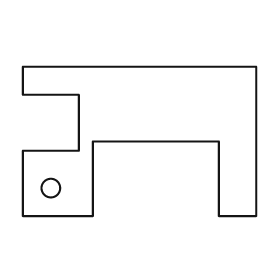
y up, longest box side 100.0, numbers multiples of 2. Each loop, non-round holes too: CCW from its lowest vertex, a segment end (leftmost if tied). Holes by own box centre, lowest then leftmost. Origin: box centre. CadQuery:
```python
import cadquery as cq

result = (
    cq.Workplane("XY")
    .moveTo(-50.0, -32.0)
    .lineTo(-20.0, -32.0)
    .lineTo(-20.0, 0.0)
    .lineTo(34.0, 0.0)
    .lineTo(34.0, -32.0)
    .lineTo(50.0, -32.0)
    .lineTo(50.0, 32.0)
    .lineTo(-50.0, 32.0)
    .lineTo(-50.0, 20.0)
    .lineTo(-26.0, 20.0)
    .lineTo(-26.0, -4.0)
    .lineTo(-50.0, -4.0)
    .close()
    .moveTo(-38.0, -20.0)
    .circle(4.0)
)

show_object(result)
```